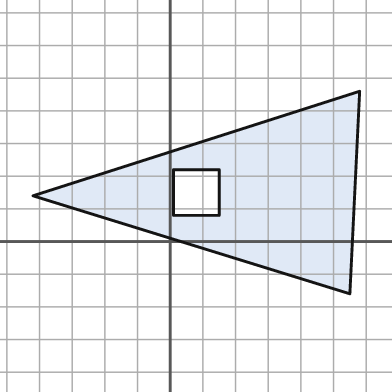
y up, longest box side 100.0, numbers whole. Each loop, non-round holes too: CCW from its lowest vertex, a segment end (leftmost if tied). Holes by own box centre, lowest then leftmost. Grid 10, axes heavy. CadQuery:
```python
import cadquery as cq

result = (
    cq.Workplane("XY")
    .moveTo(55.0, -16.0)
    .lineTo(58.0, 46.0)
    .lineTo(-42.0, 14.0)
    .close()
    .moveTo(1.0, 8.0)
    .lineTo(15.0, 8.0)
    .lineTo(15.0, 22.0)
    .lineTo(1.0, 22.0)
    .close()
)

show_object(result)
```